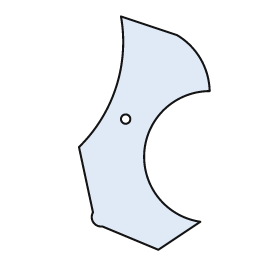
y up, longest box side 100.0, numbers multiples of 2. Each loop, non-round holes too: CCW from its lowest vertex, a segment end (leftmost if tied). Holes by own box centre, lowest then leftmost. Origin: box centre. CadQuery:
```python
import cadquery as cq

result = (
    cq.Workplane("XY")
    .moveTo(6.0, -50.0)
    .lineTo(24.0, -38.0)
    .threePointArc((0.0, -8.0), (28.0, 18.0))
    .threePointArc((24.0, 32.0), (14.0, 42.0))
    .lineTo(-10.0, 50.0)
    .threePointArc((-12.0, 20.0), (-28.0, -6.0))
    .lineTo(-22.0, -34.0)
    .threePointArc((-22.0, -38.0), (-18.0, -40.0))
    .close()
    .moveTo(-8.0, 6.0)
    .circle(2.0)
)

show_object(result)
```